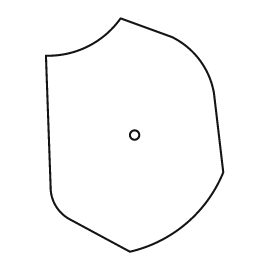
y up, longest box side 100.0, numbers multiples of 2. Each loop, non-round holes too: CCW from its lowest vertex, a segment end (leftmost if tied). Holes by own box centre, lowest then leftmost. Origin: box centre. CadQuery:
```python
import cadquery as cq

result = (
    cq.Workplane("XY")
    .moveTo(-2.0, -50.0)
    .threePointArc((22.0, -38.0), (38.0, -16.0))
    .lineTo(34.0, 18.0)
    .threePointArc((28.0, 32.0), (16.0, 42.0))
    .lineTo(-6.0, 50.0)
    .threePointArc((-20.0, 38.0), (-38.0, 34.0))
    .lineTo(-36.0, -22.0)
    .threePointArc((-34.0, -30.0), (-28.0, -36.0))
    .close()
    .moveTo(0.0, 0.0)
    .circle(2.0)
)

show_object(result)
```